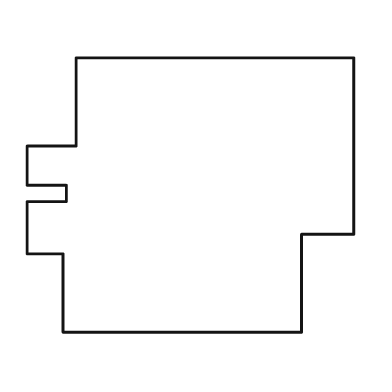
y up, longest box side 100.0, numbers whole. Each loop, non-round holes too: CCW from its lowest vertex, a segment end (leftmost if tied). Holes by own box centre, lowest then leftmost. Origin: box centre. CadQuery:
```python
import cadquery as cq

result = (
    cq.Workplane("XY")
    .moveTo(-39.0, -42.0)
    .lineTo(34.0, -42.0)
    .lineTo(34.0, -12.0)
    .lineTo(50.0, -12.0)
    .lineTo(50.0, 42.0)
    .lineTo(-35.0, 42.0)
    .lineTo(-35.0, 15.0)
    .lineTo(-50.0, 15.0)
    .lineTo(-50.0, 3.0)
    .lineTo(-38.0, 3.0)
    .lineTo(-38.0, -2.0)
    .lineTo(-50.0, -2.0)
    .lineTo(-50.0, -18.0)
    .lineTo(-39.0, -18.0)
    .close()
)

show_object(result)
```